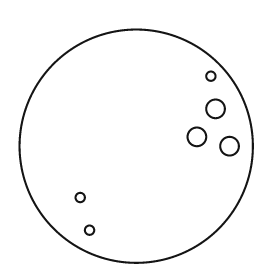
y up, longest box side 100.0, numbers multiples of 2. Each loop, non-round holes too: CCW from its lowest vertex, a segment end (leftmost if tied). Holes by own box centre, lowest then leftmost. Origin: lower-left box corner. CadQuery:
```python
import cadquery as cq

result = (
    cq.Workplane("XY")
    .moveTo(50.0, 50.0)
    .circle(50.0)
    .moveTo(30.0, 14.0)
    .circle(2.0)
    .moveTo(26.0, 28.0)
    .circle(2.0)
    .moveTo(90.0, 50.0)
    .circle(4.0)
    .moveTo(76.0, 54.0)
    .circle(4.0)
    .moveTo(84.0, 66.0)
    .circle(4.0)
    .moveTo(82.0, 80.0)
    .circle(2.0)
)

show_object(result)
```